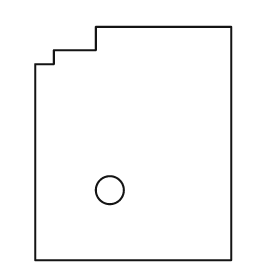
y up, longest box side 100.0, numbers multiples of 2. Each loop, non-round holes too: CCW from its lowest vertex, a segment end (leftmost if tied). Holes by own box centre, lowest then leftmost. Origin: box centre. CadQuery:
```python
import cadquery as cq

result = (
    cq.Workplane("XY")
    .moveTo(-42.0, -50.0)
    .lineTo(42.0, -50.0)
    .lineTo(42.0, 50.0)
    .lineTo(-16.0, 50.0)
    .lineTo(-16.0, 40.0)
    .lineTo(-34.0, 40.0)
    .lineTo(-34.0, 34.0)
    .lineTo(-42.0, 34.0)
    .close()
    .moveTo(-10.0, -20.0)
    .circle(6.0)
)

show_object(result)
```